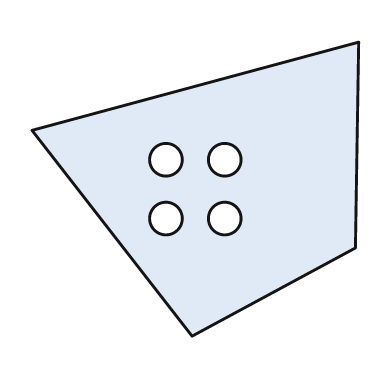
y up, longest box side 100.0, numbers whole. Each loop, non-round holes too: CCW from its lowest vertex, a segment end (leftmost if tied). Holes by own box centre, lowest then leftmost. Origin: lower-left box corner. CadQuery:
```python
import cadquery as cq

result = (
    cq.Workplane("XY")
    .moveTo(49.0, 0.0)
    .lineTo(99.0, 27.0)
    .lineTo(100.0, 90.0)
    .lineTo(0.0, 63.0)
    .close()
    .moveTo(41.0, 36.0)
    .circle(5.0)
    .moveTo(59.0, 36.0)
    .circle(5.0)
    .moveTo(41.0, 54.0)
    .circle(5.0)
    .moveTo(59.0, 54.0)
    .circle(5.0)
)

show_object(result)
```